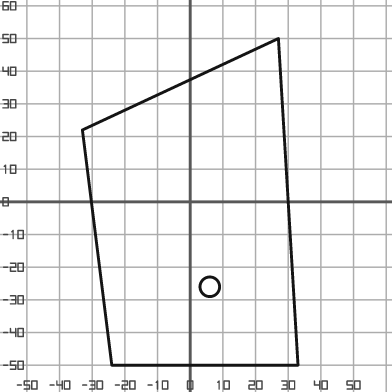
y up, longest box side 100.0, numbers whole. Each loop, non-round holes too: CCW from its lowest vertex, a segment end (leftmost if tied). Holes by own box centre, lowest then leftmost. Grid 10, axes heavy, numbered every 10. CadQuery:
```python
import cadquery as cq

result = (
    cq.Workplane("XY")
    .moveTo(-24.0, -50.0)
    .lineTo(33.0, -50.0)
    .lineTo(27.0, 50.0)
    .lineTo(-33.0, 22.0)
    .close()
    .moveTo(6.0, -26.0)
    .circle(3.0)
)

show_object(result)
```